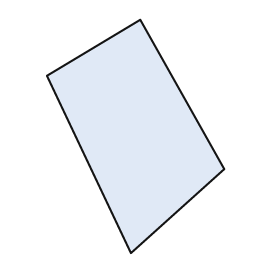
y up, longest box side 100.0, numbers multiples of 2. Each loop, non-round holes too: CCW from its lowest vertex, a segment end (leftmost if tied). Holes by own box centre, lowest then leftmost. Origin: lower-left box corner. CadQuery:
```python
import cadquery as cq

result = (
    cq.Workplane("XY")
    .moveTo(36.0, 0.0)
    .lineTo(76.0, 36.0)
    .lineTo(40.0, 100.0)
    .lineTo(0.0, 76.0)
    .close()
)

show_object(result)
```